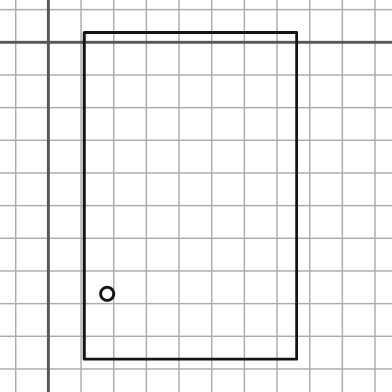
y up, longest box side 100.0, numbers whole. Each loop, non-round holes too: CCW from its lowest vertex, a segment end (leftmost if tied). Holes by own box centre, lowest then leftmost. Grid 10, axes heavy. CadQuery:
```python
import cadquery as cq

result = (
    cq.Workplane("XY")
    .moveTo(11.0, -97.0)
    .lineTo(76.0, -97.0)
    .lineTo(76.0, 3.0)
    .lineTo(11.0, 3.0)
    .close()
    .moveTo(18.0, -77.0)
    .circle(2.0)
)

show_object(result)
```